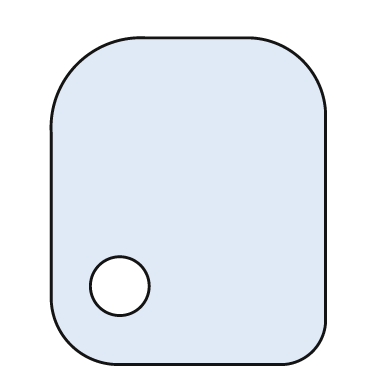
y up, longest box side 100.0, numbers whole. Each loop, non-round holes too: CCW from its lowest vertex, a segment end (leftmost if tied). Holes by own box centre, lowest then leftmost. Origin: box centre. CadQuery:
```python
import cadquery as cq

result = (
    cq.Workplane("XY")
    .moveTo(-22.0, -50.0)
    .lineTo(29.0, -50.0)
    .threePointArc((38.0, -46.0), (42.0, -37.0))
    .lineTo(42.0, 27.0)
    .threePointArc((35.0, 43.0), (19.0, 50.0))
    .lineTo(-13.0, 50.0)
    .threePointArc((-34.0, 42.0), (-42.0, 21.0))
    .lineTo(-42.0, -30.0)
    .threePointArc((-36.0, -44.0), (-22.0, -50.0))
    .close()
    .moveTo(-21.0, -26.0)
    .circle(9.0)
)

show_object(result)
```